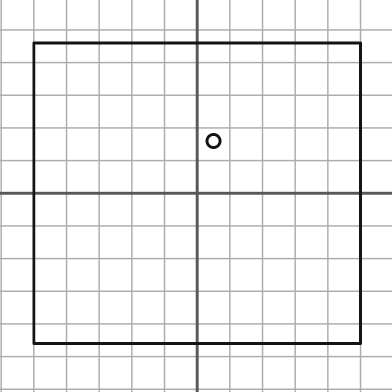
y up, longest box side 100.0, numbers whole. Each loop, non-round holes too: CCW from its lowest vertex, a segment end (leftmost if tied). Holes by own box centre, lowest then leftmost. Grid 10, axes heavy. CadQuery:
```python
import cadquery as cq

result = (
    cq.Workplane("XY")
    .moveTo(-50.0, -46.0)
    .lineTo(50.0, -46.0)
    .lineTo(50.0, 46.0)
    .lineTo(-50.0, 46.0)
    .close()
    .moveTo(5.0, 16.0)
    .circle(2.0)
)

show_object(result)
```